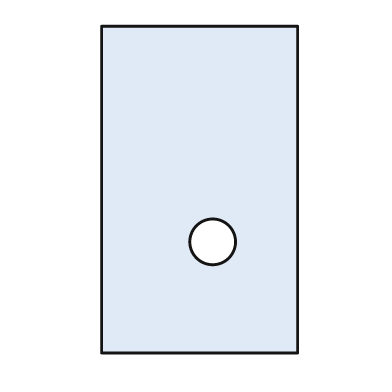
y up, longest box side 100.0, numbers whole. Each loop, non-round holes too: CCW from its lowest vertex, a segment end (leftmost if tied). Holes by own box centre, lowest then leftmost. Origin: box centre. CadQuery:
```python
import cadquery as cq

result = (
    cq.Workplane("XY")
    .moveTo(-30.0, -50.0)
    .lineTo(30.0, -50.0)
    .lineTo(30.0, 50.0)
    .lineTo(-30.0, 50.0)
    .close()
    .moveTo(4.0, -16.0)
    .circle(7.0)
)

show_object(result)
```